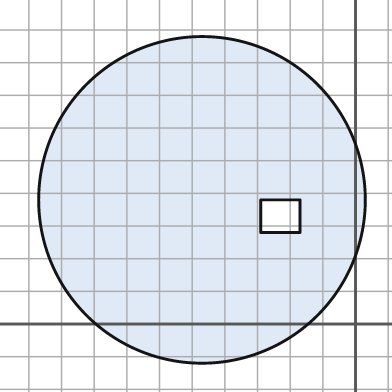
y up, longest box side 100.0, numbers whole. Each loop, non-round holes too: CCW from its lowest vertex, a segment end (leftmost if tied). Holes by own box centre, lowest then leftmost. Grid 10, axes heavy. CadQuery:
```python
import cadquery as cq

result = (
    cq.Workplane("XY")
    .moveTo(-47.0, 38.0)
    .circle(50.0)
    .moveTo(-29.0, 28.0)
    .lineTo(-17.0, 28.0)
    .lineTo(-17.0, 38.0)
    .lineTo(-29.0, 38.0)
    .close()
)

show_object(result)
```